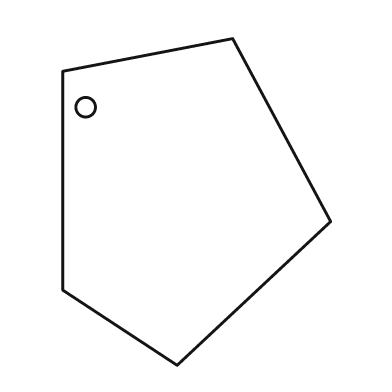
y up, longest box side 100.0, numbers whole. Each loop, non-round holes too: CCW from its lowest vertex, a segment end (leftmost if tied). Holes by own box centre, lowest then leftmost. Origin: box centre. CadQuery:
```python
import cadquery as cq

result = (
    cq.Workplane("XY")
    .moveTo(-6.0, -50.0)
    .lineTo(41.0, -6.0)
    .lineTo(11.0, 50.0)
    .lineTo(-41.0, 40.0)
    .lineTo(-41.0, -27.0)
    .close()
    .moveTo(-34.0, 29.0)
    .circle(3.0)
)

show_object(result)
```